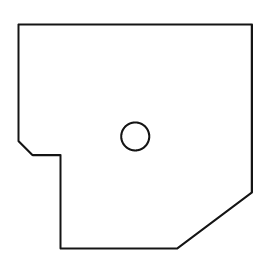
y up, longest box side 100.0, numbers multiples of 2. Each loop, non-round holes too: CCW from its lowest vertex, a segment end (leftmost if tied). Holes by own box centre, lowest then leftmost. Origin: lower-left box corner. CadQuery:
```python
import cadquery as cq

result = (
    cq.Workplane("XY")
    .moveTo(18.0, 0.0)
    .lineTo(68.0, 0.0)
    .lineTo(100.0, 24.0)
    .lineTo(100.0, 96.0)
    .lineTo(0.0, 96.0)
    .lineTo(0.0, 46.0)
    .lineTo(6.0, 40.0)
    .lineTo(18.0, 40.0)
    .close()
    .moveTo(50.0, 48.0)
    .circle(6.0)
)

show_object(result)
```